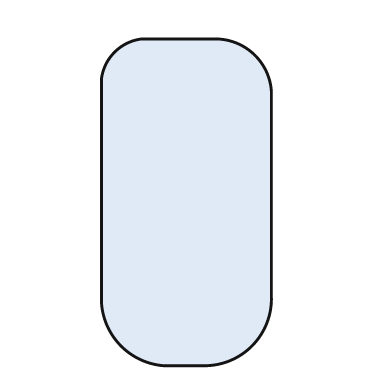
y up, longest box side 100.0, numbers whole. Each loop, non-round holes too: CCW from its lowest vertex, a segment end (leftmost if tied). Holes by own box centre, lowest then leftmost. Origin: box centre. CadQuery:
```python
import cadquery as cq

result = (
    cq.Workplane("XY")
    .moveTo(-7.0, -50.0)
    .lineTo(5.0, -50.0)
    .threePointArc((20.0, -44.0), (26.0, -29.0))
    .lineTo(26.0, 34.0)
    .threePointArc((21.0, 45.0), (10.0, 50.0))
    .lineTo(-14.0, 50.0)
    .threePointArc((-22.0, 46.0), (-26.0, 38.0))
    .lineTo(-26.0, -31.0)
    .threePointArc((-20.0, -44.0), (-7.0, -50.0))
    .close()
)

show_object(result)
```